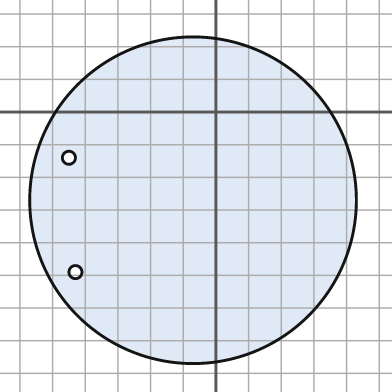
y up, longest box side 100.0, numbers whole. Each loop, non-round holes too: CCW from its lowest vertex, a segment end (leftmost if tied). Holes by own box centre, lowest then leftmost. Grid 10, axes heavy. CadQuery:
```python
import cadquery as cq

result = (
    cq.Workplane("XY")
    .moveTo(-7.0, -27.0)
    .circle(50.0)
    .moveTo(-43.0, -49.0)
    .circle(2.0)
    .moveTo(-45.0, -14.0)
    .circle(2.0)
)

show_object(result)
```